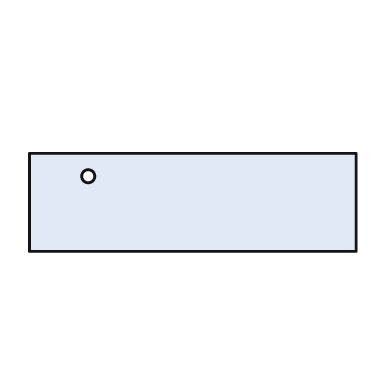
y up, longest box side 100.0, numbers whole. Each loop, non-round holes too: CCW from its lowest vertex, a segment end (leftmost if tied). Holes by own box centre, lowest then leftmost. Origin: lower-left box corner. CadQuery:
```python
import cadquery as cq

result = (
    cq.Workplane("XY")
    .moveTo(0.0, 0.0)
    .lineTo(100.0, 0.0)
    .lineTo(100.0, 30.0)
    .lineTo(0.0, 30.0)
    .close()
    .moveTo(18.0, 23.0)
    .circle(2.0)
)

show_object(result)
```